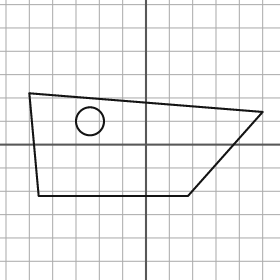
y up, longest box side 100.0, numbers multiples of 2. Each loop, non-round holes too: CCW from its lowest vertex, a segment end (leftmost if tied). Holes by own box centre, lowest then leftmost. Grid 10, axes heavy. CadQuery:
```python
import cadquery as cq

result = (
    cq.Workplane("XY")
    .moveTo(-46.0, -22.0)
    .lineTo(18.0, -22.0)
    .lineTo(50.0, 14.0)
    .lineTo(-50.0, 22.0)
    .close()
    .moveTo(-24.0, 10.0)
    .circle(6.0)
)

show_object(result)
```